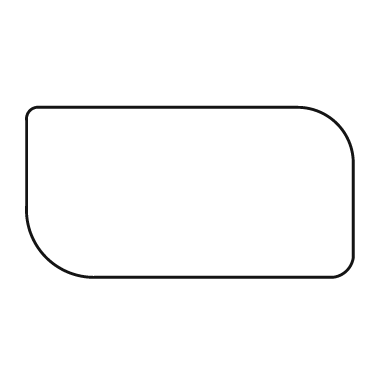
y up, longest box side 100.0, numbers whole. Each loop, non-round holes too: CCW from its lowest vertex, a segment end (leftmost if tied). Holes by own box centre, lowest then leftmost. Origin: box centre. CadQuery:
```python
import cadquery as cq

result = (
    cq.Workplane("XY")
    .moveTo(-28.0, -26.0)
    .lineTo(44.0, -26.0)
    .threePointArc((48.0, -24.0), (50.0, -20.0))
    .lineTo(50.0, 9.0)
    .threePointArc((45.0, 21.0), (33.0, 26.0))
    .lineTo(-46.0, 26.0)
    .threePointArc((-49.0, 25.0), (-50.0, 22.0))
    .lineTo(-50.0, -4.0)
    .threePointArc((-44.0, -20.0), (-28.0, -26.0))
    .close()
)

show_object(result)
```